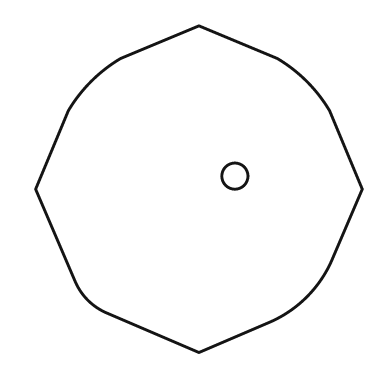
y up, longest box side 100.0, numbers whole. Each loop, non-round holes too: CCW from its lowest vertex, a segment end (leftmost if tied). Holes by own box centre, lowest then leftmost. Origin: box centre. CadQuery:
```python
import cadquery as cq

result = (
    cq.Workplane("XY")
    .moveTo(0.0, -50.0)
    .lineTo(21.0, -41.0)
    .threePointArc((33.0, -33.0), (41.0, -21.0))
    .lineTo(50.0, 0.0)
    .lineTo(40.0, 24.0)
    .threePointArc((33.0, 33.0), (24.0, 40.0))
    .lineTo(0.0, 50.0)
    .lineTo(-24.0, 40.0)
    .threePointArc((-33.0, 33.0), (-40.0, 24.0))
    .lineTo(-50.0, 0.0)
    .lineTo(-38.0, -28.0)
    .threePointArc((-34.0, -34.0), (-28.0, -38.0))
    .close()
    .moveTo(11.0, 4.0)
    .circle(4.0)
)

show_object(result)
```